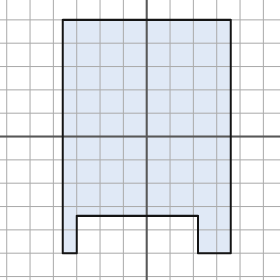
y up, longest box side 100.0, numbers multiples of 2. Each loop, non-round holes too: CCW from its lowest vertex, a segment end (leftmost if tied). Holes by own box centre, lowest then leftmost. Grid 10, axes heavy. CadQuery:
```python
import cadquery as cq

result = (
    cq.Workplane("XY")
    .moveTo(-36.0, -50.0)
    .lineTo(-30.0, -50.0)
    .lineTo(-30.0, -34.0)
    .lineTo(22.0, -34.0)
    .lineTo(22.0, -50.0)
    .lineTo(36.0, -50.0)
    .lineTo(36.0, 50.0)
    .lineTo(-36.0, 50.0)
    .close()
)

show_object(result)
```